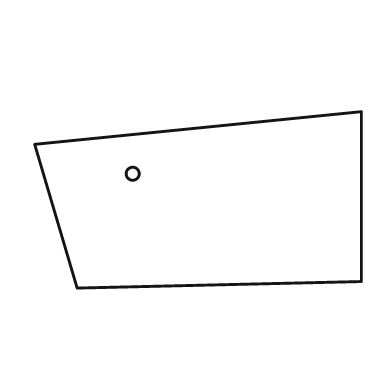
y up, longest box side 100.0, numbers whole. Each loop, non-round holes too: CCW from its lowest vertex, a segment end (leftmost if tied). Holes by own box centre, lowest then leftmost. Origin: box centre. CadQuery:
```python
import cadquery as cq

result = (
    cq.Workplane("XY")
    .moveTo(-37.0, -27.0)
    .lineTo(50.0, -25.0)
    .lineTo(50.0, 27.0)
    .lineTo(-50.0, 17.0)
    .close()
    .moveTo(-20.0, 8.0)
    .circle(2.0)
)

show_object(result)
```